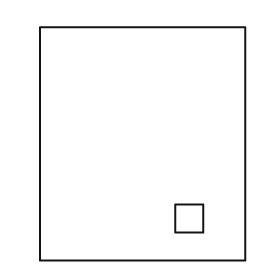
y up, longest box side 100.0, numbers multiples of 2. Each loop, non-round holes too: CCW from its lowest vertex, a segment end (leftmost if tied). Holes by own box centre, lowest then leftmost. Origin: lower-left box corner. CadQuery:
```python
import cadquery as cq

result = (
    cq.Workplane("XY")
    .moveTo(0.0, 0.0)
    .lineTo(88.0, 0.0)
    .lineTo(88.0, 100.0)
    .lineTo(0.0, 100.0)
    .close()
    .moveTo(58.0, 12.0)
    .lineTo(70.0, 12.0)
    .lineTo(70.0, 24.0)
    .lineTo(58.0, 24.0)
    .close()
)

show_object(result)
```